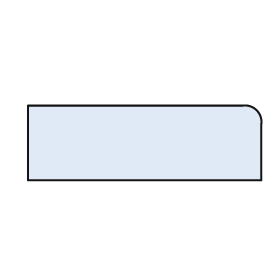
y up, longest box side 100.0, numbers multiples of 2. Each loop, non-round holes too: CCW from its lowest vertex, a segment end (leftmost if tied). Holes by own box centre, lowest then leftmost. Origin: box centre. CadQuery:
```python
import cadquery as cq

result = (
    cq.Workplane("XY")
    .moveTo(-50.0, -16.0)
    .lineTo(50.0, -16.0)
    .lineTo(50.0, 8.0)
    .threePointArc((48.0, 14.0), (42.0, 16.0))
    .lineTo(-50.0, 16.0)
    .close()
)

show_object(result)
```